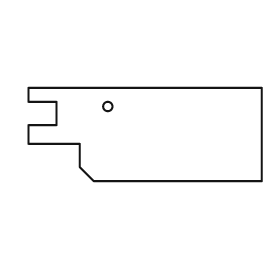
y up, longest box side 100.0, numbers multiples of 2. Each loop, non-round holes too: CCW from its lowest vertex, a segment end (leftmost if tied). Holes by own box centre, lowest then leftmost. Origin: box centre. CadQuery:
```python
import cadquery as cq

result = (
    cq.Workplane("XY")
    .moveTo(-22.0, -20.0)
    .lineTo(50.0, -20.0)
    .lineTo(50.0, 20.0)
    .lineTo(-50.0, 20.0)
    .lineTo(-50.0, 14.0)
    .lineTo(-38.0, 14.0)
    .lineTo(-38.0, 4.0)
    .lineTo(-50.0, 4.0)
    .lineTo(-50.0, -4.0)
    .lineTo(-28.0, -4.0)
    .lineTo(-28.0, -14.0)
    .close()
    .moveTo(-16.0, 12.0)
    .circle(2.0)
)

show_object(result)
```